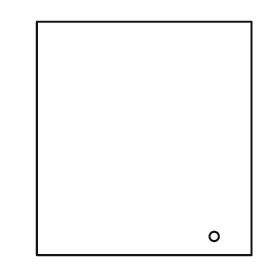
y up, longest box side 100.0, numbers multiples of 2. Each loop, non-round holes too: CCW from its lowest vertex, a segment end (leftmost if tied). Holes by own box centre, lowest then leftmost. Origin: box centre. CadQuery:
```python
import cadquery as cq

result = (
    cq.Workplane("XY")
    .moveTo(-46.0, -50.0)
    .lineTo(46.0, -50.0)
    .lineTo(46.0, 50.0)
    .lineTo(-46.0, 50.0)
    .close()
    .moveTo(30.0, -42.0)
    .circle(2.0)
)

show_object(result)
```